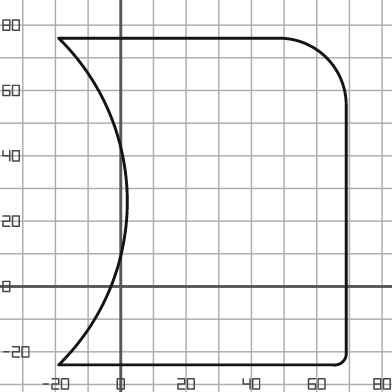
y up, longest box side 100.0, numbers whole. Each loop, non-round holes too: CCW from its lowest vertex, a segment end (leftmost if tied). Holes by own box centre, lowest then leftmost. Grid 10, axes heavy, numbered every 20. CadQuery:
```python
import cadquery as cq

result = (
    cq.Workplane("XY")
    .moveTo(-19.0, -24.0)
    .lineTo(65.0, -24.0)
    .threePointArc((68.0, -23.0), (69.0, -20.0))
    .lineTo(69.0, 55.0)
    .threePointArc((63.0, 70.0), (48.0, 76.0))
    .lineTo(-19.0, 76.0)
    .threePointArc((2.0, 26.0), (-19.0, -24.0))
    .close()
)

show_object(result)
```